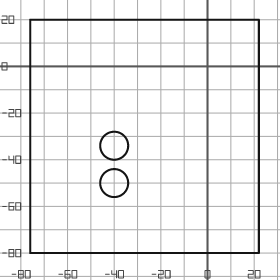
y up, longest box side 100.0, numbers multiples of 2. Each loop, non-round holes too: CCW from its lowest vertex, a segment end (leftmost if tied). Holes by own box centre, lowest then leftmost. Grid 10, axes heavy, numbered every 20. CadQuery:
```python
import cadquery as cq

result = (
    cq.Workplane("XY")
    .moveTo(-76.0, -80.0)
    .lineTo(22.0, -80.0)
    .lineTo(22.0, 20.0)
    .lineTo(-76.0, 20.0)
    .close()
    .moveTo(-40.0, -50.0)
    .circle(6.0)
    .moveTo(-40.0, -34.0)
    .circle(6.0)
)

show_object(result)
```